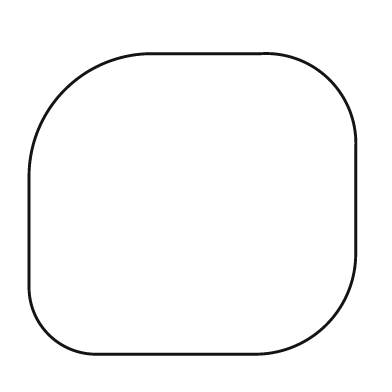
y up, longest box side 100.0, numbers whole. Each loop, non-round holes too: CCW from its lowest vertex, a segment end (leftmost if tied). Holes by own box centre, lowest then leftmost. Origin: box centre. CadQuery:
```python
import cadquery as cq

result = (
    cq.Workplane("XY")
    .moveTo(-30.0, -46.0)
    .lineTo(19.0, -46.0)
    .threePointArc((41.0, -37.0), (50.0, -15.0))
    .lineTo(50.0, 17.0)
    .threePointArc((42.0, 38.0), (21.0, 46.0))
    .lineTo(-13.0, 46.0)
    .threePointArc((-39.0, 35.0), (-50.0, 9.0))
    .lineTo(-50.0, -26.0)
    .threePointArc((-44.0, -40.0), (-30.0, -46.0))
    .close()
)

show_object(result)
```